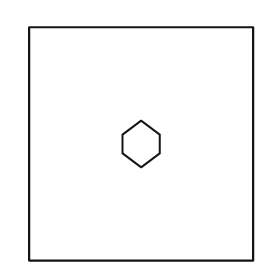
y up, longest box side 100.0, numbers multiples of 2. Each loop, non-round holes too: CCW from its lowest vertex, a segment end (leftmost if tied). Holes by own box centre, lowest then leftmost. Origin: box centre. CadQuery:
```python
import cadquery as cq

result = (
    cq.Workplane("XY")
    .moveTo(-48.0, -50.0)
    .lineTo(48.0, -50.0)
    .lineTo(48.0, 50.0)
    .lineTo(-48.0, 50.0)
    .close()
    .moveTo(0.0, -10.0)
    .lineTo(8.0, -4.0)
    .lineTo(8.0, 4.0)
    .lineTo(0.0, 10.0)
    .lineTo(-8.0, 4.0)
    .lineTo(-8.0, -4.0)
    .close()
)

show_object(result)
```